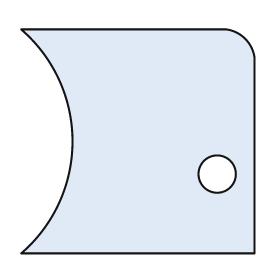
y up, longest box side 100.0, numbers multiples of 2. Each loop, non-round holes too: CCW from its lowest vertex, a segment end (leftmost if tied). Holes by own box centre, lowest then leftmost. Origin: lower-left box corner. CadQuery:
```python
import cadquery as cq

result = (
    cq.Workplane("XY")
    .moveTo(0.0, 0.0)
    .lineTo(100.0, 0.0)
    .lineTo(100.0, 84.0)
    .threePointArc((96.0, 92.0), (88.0, 96.0))
    .lineTo(0.0, 96.0)
    .threePointArc((22.0, 48.0), (0.0, 0.0))
    .close()
    .moveTo(84.0, 34.0)
    .circle(8.0)
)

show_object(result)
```